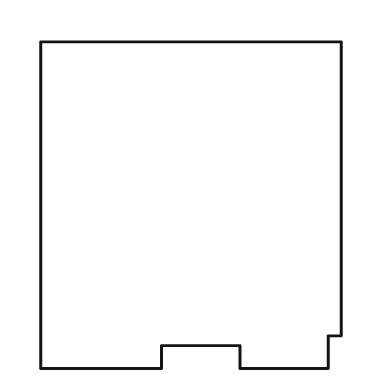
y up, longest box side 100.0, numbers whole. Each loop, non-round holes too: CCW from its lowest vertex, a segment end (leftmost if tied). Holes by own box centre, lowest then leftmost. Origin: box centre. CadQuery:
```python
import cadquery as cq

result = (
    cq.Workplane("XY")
    .moveTo(-46.0, -50.0)
    .lineTo(-9.0, -50.0)
    .lineTo(-9.0, -43.0)
    .lineTo(15.0, -43.0)
    .lineTo(15.0, -50.0)
    .lineTo(42.0, -50.0)
    .lineTo(42.0, -40.0)
    .lineTo(46.0, -40.0)
    .lineTo(46.0, 50.0)
    .lineTo(-46.0, 50.0)
    .close()
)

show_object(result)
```